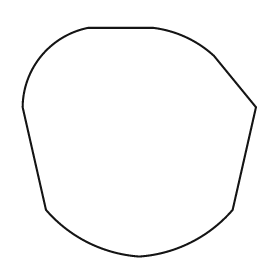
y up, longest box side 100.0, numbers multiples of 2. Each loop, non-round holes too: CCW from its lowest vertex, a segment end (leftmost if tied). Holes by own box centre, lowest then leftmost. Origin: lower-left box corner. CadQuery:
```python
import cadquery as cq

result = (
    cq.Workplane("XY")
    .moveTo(50.0, 0.0)
    .threePointArc((72.0, 6.0), (90.0, 20.0))
    .lineTo(100.0, 64.0)
    .lineTo(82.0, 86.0)
    .threePointArc((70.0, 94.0), (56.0, 98.0))
    .lineTo(28.0, 98.0)
    .threePointArc((8.0, 86.0), (0.0, 64.0))
    .lineTo(10.0, 20.0)
    .threePointArc((28.0, 6.0), (50.0, 0.0))
    .close()
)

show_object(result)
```